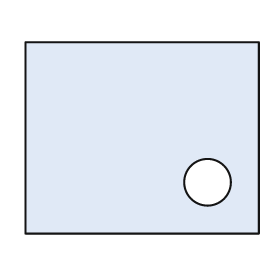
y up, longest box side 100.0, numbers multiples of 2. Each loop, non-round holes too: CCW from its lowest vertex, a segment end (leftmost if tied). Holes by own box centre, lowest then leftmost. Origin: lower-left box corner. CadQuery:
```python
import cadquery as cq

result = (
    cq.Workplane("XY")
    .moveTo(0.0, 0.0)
    .lineTo(100.0, 0.0)
    .lineTo(100.0, 82.0)
    .lineTo(0.0, 82.0)
    .close()
    .moveTo(78.0, 22.0)
    .circle(10.0)
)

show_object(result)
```